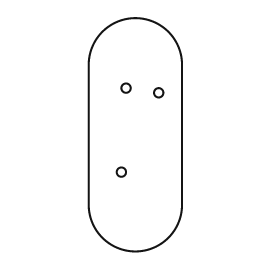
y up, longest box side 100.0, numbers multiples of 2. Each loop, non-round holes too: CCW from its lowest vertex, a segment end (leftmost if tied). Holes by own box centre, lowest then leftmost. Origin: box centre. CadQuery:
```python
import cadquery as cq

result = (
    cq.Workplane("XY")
    .moveTo(-20.0, -30.0)
    .threePointArc((0.0, -50.0), (20.0, -30.0))
    .lineTo(20.0, 30.0)
    .threePointArc((0.0, 50.0), (-20.0, 30.0))
    .close()
    .moveTo(-6.0, -16.0)
    .circle(2.0)
    .moveTo(10.0, 18.0)
    .circle(2.0)
    .moveTo(-4.0, 20.0)
    .circle(2.0)
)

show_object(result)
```